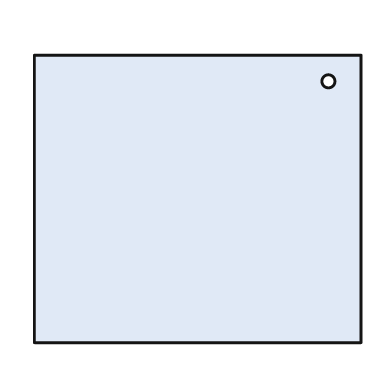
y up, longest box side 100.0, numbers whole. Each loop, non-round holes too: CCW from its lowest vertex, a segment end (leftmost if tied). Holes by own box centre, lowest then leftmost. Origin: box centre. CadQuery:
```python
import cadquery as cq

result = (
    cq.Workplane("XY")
    .moveTo(-50.0, -44.0)
    .lineTo(50.0, -44.0)
    .lineTo(50.0, 44.0)
    .lineTo(-50.0, 44.0)
    .close()
    .moveTo(40.0, 36.0)
    .circle(2.0)
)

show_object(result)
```